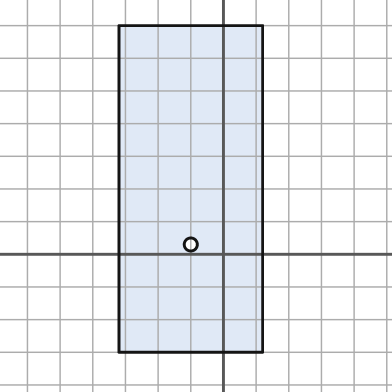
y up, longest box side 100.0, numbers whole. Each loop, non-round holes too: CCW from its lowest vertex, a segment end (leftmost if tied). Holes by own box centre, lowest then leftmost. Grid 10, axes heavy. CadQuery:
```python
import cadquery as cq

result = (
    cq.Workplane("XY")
    .moveTo(-32.0, -30.0)
    .lineTo(12.0, -30.0)
    .lineTo(12.0, 70.0)
    .lineTo(-32.0, 70.0)
    .close()
    .moveTo(-10.0, 3.0)
    .circle(2.0)
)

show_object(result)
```